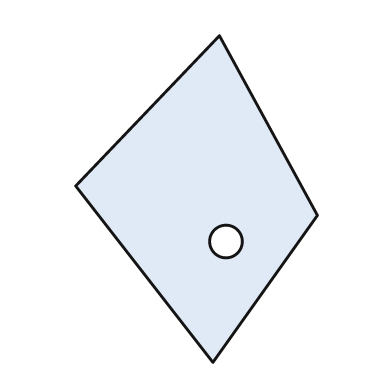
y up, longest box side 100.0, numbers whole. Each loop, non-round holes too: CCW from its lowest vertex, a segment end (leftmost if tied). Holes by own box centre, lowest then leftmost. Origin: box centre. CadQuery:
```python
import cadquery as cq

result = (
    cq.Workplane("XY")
    .moveTo(5.0, -50.0)
    .lineTo(37.0, -5.0)
    .lineTo(7.0, 50.0)
    .lineTo(-37.0, 4.0)
    .close()
    .moveTo(9.0, -13.0)
    .circle(5.0)
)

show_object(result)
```